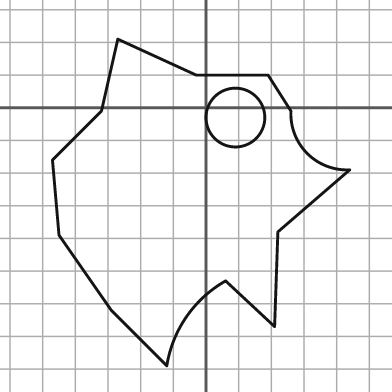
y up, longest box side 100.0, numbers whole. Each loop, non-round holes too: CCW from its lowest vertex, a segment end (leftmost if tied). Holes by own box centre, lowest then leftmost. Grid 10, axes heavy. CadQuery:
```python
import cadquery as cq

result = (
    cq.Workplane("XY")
    .moveTo(-12.0, -79.0)
    .threePointArc((-6.0, -64.0), (6.0, -53.0))
    .lineTo(21.0, -67.0)
    .lineTo(22.0, -38.0)
    .lineTo(44.0, -19.0)
    .threePointArc((31.0, -14.0), (26.0, -1.0))
    .lineTo(19.0, 10.0)
    .lineTo(-3.0, 10.0)
    .lineTo(-27.0, 21.0)
    .lineTo(-32.0, -1.0)
    .lineTo(-47.0, -16.0)
    .lineTo(-45.0, -39.0)
    .lineTo(-29.0, -62.0)
    .close()
    .moveTo(9.0, -3.0)
    .circle(9.0)
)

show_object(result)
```